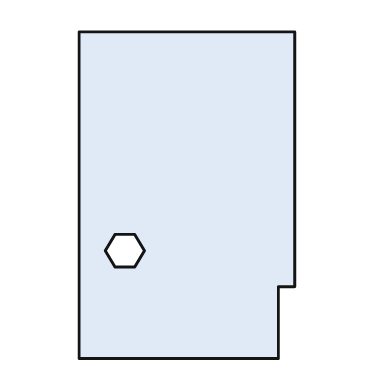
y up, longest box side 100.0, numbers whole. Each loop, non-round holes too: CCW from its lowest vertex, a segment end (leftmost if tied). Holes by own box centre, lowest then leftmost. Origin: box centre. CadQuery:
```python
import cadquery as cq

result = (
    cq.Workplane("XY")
    .moveTo(-33.0, -50.0)
    .lineTo(28.0, -50.0)
    .lineTo(28.0, -28.0)
    .lineTo(33.0, -28.0)
    .lineTo(33.0, 50.0)
    .lineTo(-33.0, 50.0)
    .close()
    .moveTo(-22.0, -22.0)
    .lineTo(-16.0, -22.0)
    .lineTo(-13.0, -17.0)
    .lineTo(-16.0, -12.0)
    .lineTo(-22.0, -12.0)
    .lineTo(-25.0, -17.0)
    .close()
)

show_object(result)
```